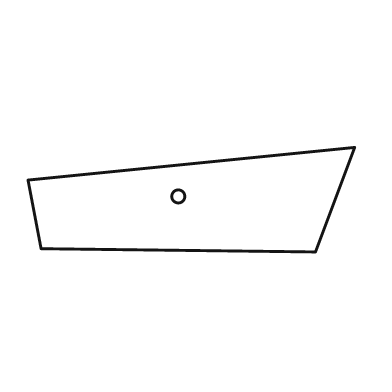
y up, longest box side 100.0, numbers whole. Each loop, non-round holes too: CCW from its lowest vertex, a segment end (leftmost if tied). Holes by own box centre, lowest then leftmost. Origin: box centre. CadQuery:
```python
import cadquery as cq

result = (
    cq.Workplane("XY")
    .moveTo(38.0, -16.0)
    .lineTo(50.0, 16.0)
    .lineTo(-50.0, 6.0)
    .lineTo(-46.0, -15.0)
    .close()
    .moveTo(-4.0, 1.0)
    .circle(2.0)
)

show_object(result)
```